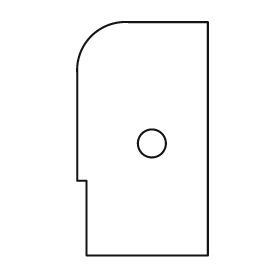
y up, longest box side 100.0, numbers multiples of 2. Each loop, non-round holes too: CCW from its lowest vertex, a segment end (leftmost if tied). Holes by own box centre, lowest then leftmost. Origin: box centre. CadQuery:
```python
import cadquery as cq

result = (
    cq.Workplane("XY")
    .moveTo(-24.0, -50.0)
    .lineTo(28.0, -50.0)
    .lineTo(28.0, 50.0)
    .lineTo(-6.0, 50.0)
    .threePointArc((-22.0, 44.0), (-28.0, 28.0))
    .lineTo(-28.0, -18.0)
    .lineTo(-24.0, -18.0)
    .close()
    .moveTo(4.0, -2.0)
    .circle(6.0)
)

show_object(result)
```